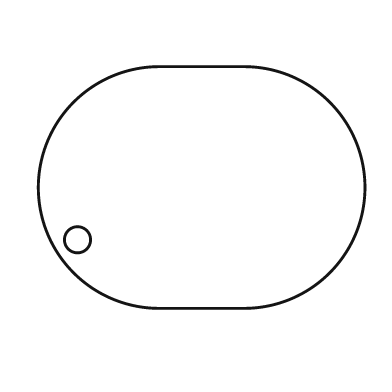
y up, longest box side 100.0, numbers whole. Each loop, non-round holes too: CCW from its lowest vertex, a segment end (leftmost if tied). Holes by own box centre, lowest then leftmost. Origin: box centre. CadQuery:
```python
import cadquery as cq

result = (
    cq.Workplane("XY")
    .moveTo(-13.0, -37.0)
    .lineTo(13.0, -37.0)
    .threePointArc((50.0, 0.0), (13.0, 37.0))
    .lineTo(-13.0, 37.0)
    .threePointArc((-50.0, 0.0), (-13.0, -37.0))
    .close()
    .moveTo(-38.0, -16.0)
    .circle(4.0)
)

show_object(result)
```